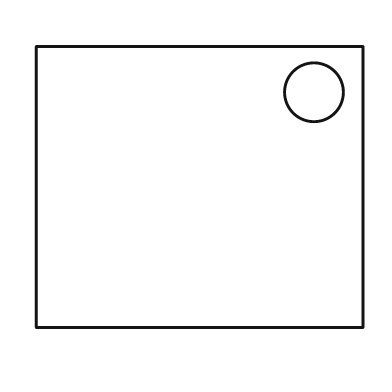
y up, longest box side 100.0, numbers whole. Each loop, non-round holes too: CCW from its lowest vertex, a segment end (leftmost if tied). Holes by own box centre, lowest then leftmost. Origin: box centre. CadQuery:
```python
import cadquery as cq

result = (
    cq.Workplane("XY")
    .moveTo(-50.0, -43.0)
    .lineTo(50.0, -43.0)
    .lineTo(50.0, 43.0)
    .lineTo(-50.0, 43.0)
    .close()
    .moveTo(35.0, 29.0)
    .circle(9.0)
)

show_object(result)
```